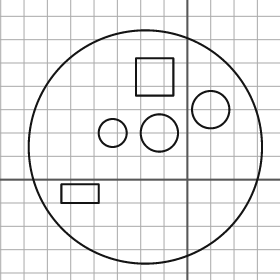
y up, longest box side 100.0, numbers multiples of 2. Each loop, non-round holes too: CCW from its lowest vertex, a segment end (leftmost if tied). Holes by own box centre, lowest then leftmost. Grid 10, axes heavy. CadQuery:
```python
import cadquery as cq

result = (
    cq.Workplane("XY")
    .moveTo(-18.0, 14.0)
    .circle(50.0)
    .moveTo(-54.0, -10.0)
    .lineTo(-38.0, -10.0)
    .lineTo(-38.0, -2.0)
    .lineTo(-54.0, -2.0)
    .close()
    .moveTo(-32.0, 20.0)
    .circle(6.0)
    .moveTo(-12.0, 20.0)
    .circle(8.0)
    .moveTo(10.0, 30.0)
    .circle(8.0)
    .moveTo(-22.0, 36.0)
    .lineTo(-6.0, 36.0)
    .lineTo(-6.0, 52.0)
    .lineTo(-22.0, 52.0)
    .close()
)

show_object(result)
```